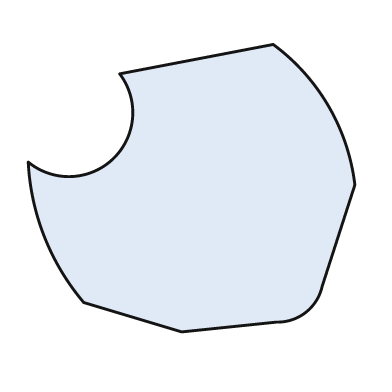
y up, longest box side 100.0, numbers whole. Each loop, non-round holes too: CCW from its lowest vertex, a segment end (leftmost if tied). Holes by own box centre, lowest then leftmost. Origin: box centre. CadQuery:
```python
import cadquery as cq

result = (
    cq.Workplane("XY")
    .moveTo(-3.0, -44.0)
    .lineTo(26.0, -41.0)
    .threePointArc((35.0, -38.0), (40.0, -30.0))
    .lineTo(50.0, 1.0)
    .threePointArc((42.0, 25.0), (25.0, 44.0))
    .lineTo(-22.0, 35.0)
    .threePointArc((-24.0, 9.0), (-50.0, 8.0))
    .threePointArc((-45.0, -15.0), (-33.0, -35.0))
    .close()
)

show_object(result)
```